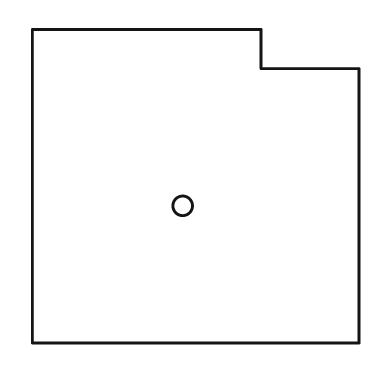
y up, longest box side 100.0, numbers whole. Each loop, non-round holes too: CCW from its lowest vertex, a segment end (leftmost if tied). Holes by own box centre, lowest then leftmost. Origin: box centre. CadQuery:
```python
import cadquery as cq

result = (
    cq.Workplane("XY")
    .moveTo(-50.0, -48.0)
    .lineTo(50.0, -48.0)
    .lineTo(50.0, 36.0)
    .lineTo(20.0, 36.0)
    .lineTo(20.0, 48.0)
    .lineTo(-50.0, 48.0)
    .close()
    .moveTo(-4.0, -6.0)
    .circle(3.0)
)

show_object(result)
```